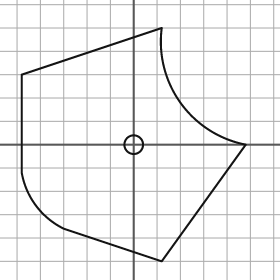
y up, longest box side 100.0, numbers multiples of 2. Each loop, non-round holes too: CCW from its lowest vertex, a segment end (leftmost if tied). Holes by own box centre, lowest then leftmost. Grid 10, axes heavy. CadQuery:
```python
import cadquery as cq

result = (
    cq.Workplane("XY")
    .moveTo(12.0, -50.0)
    .lineTo(48.0, 0.0)
    .threePointArc((20.0, 18.0), (12.0, 50.0))
    .lineTo(-48.0, 30.0)
    .lineTo(-48.0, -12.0)
    .threePointArc((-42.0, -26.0), (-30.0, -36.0))
    .close()
    .moveTo(0.0, 0.0)
    .circle(4.0)
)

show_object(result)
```